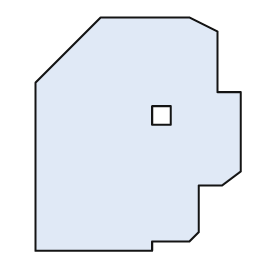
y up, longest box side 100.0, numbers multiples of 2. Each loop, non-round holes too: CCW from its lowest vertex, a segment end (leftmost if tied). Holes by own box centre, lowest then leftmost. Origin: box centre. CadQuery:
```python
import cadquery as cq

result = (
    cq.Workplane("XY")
    .moveTo(-44.0, -50.0)
    .lineTo(6.0, -50.0)
    .lineTo(6.0, -46.0)
    .lineTo(22.0, -46.0)
    .lineTo(26.0, -42.0)
    .lineTo(26.0, -22.0)
    .lineTo(36.0, -22.0)
    .lineTo(44.0, -16.0)
    .lineTo(44.0, 18.0)
    .lineTo(34.0, 18.0)
    .lineTo(34.0, 44.0)
    .lineTo(22.0, 50.0)
    .lineTo(-16.0, 50.0)
    .lineTo(-44.0, 22.0)
    .close()
    .moveTo(6.0, 4.0)
    .lineTo(14.0, 4.0)
    .lineTo(14.0, 12.0)
    .lineTo(6.0, 12.0)
    .close()
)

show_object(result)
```